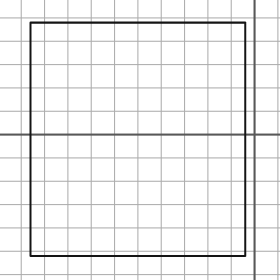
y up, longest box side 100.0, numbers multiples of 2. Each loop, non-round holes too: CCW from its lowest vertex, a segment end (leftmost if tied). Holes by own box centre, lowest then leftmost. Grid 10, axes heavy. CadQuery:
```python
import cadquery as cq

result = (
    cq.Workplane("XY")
    .moveTo(-96.0, -52.0)
    .lineTo(-4.0, -52.0)
    .lineTo(-4.0, 48.0)
    .lineTo(-96.0, 48.0)
    .close()
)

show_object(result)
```